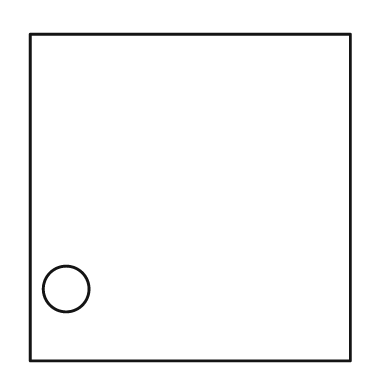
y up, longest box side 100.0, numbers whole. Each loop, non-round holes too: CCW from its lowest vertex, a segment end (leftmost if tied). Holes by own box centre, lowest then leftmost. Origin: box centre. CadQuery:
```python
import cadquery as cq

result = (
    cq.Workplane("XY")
    .moveTo(-49.0, -50.0)
    .lineTo(49.0, -50.0)
    .lineTo(49.0, 50.0)
    .lineTo(-49.0, 50.0)
    .close()
    .moveTo(-38.0, -28.0)
    .circle(7.0)
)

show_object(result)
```